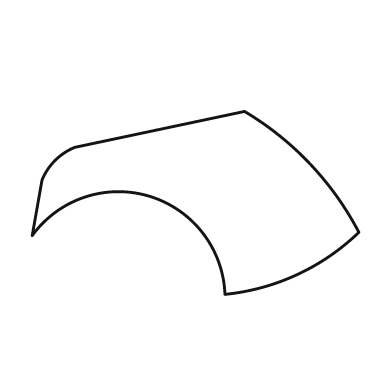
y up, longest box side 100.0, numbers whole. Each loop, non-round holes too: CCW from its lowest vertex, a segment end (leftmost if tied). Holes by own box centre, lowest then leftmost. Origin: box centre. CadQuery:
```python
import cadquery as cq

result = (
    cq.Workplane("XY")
    .moveTo(9.0, -28.0)
    .threePointArc((31.0, -22.0), (50.0, -9.0))
    .threePointArc((35.0, 12.0), (15.0, 28.0))
    .lineTo(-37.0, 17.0)
    .threePointArc((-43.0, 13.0), (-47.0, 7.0))
    .lineTo(-50.0, -10.0)
    .threePointArc((-14.0, 2.0), (9.0, -28.0))
    .close()
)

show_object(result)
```